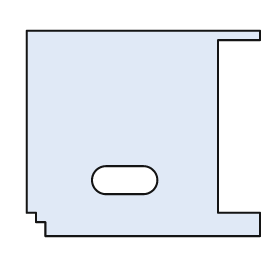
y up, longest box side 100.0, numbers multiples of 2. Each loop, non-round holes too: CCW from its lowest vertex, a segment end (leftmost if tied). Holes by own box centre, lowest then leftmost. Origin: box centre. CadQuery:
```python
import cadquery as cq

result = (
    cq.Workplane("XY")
    .moveTo(-42.0, -44.0)
    .lineTo(50.0, -44.0)
    .lineTo(50.0, -34.0)
    .lineTo(32.0, -34.0)
    .lineTo(32.0, 40.0)
    .lineTo(50.0, 40.0)
    .lineTo(50.0, 44.0)
    .lineTo(-50.0, 44.0)
    .lineTo(-50.0, -34.0)
    .lineTo(-46.0, -34.0)
    .lineTo(-46.0, -38.0)
    .lineTo(-42.0, -38.0)
    .close()
    .moveTo(-16.0, -26.0)
    .lineTo(0.0, -26.0)
    .threePointArc((6.0, -20.0), (0.0, -14.0))
    .lineTo(-16.0, -14.0)
    .threePointArc((-22.0, -20.0), (-16.0, -26.0))
    .close()
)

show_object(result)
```